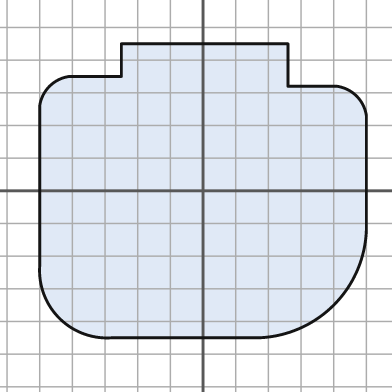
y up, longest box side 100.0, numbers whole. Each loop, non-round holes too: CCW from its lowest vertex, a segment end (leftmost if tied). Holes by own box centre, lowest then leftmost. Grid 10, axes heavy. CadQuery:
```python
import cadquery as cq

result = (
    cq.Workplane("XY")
    .moveTo(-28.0, -45.0)
    .lineTo(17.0, -45.0)
    .threePointArc((40.0, -35.0), (50.0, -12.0))
    .lineTo(50.0, 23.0)
    .threePointArc((47.0, 29.0), (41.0, 32.0))
    .lineTo(26.0, 32.0)
    .lineTo(26.0, 45.0)
    .lineTo(-25.0, 45.0)
    .lineTo(-25.0, 35.0)
    .lineTo(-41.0, 35.0)
    .threePointArc((-47.0, 32.0), (-50.0, 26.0))
    .lineTo(-50.0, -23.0)
    .threePointArc((-44.0, -39.0), (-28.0, -45.0))
    .close()
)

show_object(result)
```